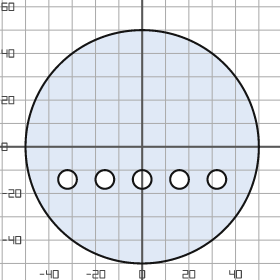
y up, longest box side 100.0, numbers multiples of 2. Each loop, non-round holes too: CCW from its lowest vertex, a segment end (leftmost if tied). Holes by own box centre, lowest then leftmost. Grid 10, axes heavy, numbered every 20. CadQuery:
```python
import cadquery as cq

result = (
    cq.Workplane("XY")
    .moveTo(0.0, 0.0)
    .circle(50.0)
    .moveTo(-32.0, -14.0)
    .circle(4.0)
    .moveTo(-16.0, -14.0)
    .circle(4.0)
    .moveTo(0.0, -14.0)
    .circle(4.0)
    .moveTo(16.0, -14.0)
    .circle(4.0)
    .moveTo(32.0, -14.0)
    .circle(4.0)
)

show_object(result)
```